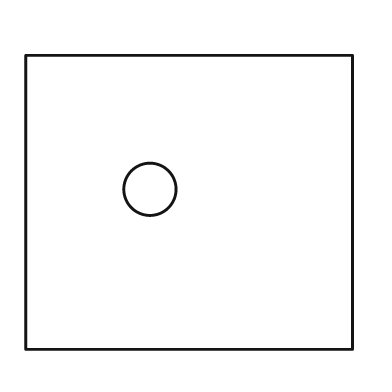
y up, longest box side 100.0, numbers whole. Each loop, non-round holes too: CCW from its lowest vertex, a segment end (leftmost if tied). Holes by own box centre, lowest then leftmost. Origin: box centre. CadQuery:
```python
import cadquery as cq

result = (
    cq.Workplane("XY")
    .moveTo(-50.0, -45.0)
    .lineTo(50.0, -45.0)
    .lineTo(50.0, 45.0)
    .lineTo(-50.0, 45.0)
    .close()
    .moveTo(-12.0, 4.0)
    .circle(8.0)
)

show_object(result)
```